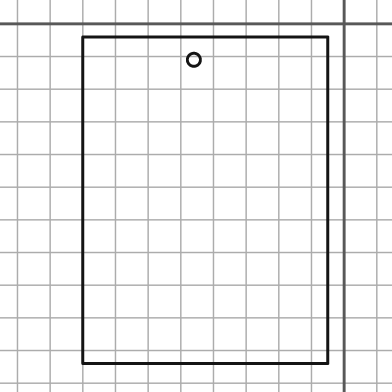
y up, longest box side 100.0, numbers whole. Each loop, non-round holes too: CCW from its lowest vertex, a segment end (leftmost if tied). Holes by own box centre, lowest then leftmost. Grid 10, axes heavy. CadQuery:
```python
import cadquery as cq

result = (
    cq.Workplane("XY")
    .moveTo(-80.0, -104.0)
    .lineTo(-5.0, -104.0)
    .lineTo(-5.0, -4.0)
    .lineTo(-80.0, -4.0)
    .close()
    .moveTo(-46.0, -11.0)
    .circle(2.0)
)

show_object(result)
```